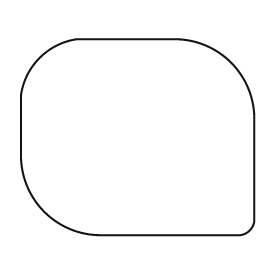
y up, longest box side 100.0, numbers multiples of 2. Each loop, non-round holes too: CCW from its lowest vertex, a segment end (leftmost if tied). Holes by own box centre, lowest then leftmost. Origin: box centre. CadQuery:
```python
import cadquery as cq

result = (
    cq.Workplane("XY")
    .moveTo(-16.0, -42.0)
    .lineTo(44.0, -42.0)
    .threePointArc((48.0, -40.0), (50.0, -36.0))
    .lineTo(50.0, 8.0)
    .threePointArc((40.0, 32.0), (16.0, 42.0))
    .lineTo(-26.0, 42.0)
    .threePointArc((-42.0, 34.0), (-50.0, 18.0))
    .lineTo(-50.0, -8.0)
    .threePointArc((-40.0, -32.0), (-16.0, -42.0))
    .close()
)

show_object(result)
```